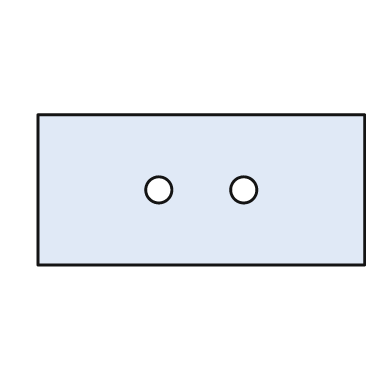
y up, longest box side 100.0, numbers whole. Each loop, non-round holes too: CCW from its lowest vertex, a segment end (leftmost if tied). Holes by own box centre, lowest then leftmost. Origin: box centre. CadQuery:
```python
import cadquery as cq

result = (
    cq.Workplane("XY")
    .moveTo(-50.0, -23.0)
    .lineTo(50.0, -23.0)
    .lineTo(50.0, 23.0)
    .lineTo(-50.0, 23.0)
    .close()
    .moveTo(-13.0, 0.0)
    .circle(4.0)
    .moveTo(13.0, 0.0)
    .circle(4.0)
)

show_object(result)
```